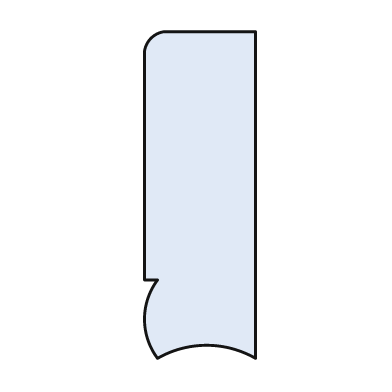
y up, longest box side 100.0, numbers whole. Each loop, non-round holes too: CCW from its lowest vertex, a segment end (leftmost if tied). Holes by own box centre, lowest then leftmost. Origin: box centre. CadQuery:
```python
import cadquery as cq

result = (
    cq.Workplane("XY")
    .moveTo(-13.0, -50.0)
    .threePointArc((2.0, -46.0), (17.0, -50.0))
    .lineTo(17.0, 50.0)
    .lineTo(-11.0, 50.0)
    .threePointArc((-15.0, 48.0), (-17.0, 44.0))
    .lineTo(-17.0, -26.0)
    .lineTo(-13.0, -26.0)
    .threePointArc((-17.0, -38.0), (-13.0, -50.0))
    .close()
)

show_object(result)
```